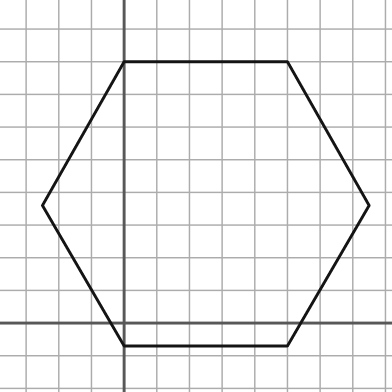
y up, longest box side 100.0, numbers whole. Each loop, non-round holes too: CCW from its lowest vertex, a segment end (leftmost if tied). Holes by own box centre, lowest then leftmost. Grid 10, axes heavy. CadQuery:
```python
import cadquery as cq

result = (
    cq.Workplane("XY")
    .moveTo(0.0, -7.0)
    .lineTo(50.0, -7.0)
    .lineTo(75.0, 36.0)
    .lineTo(50.0, 80.0)
    .lineTo(0.0, 80.0)
    .lineTo(-25.0, 36.0)
    .close()
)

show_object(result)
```